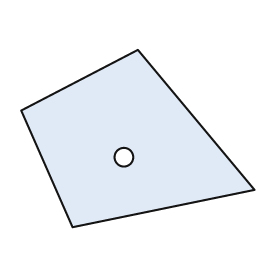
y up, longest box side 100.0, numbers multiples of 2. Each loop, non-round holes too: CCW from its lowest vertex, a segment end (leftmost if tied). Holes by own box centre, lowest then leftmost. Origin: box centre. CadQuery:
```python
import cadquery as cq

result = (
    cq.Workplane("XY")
    .moveTo(-28.0, -38.0)
    .lineTo(50.0, -22.0)
    .lineTo(0.0, 38.0)
    .lineTo(-50.0, 12.0)
    .close()
    .moveTo(-6.0, -8.0)
    .circle(4.0)
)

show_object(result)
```